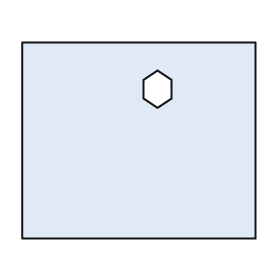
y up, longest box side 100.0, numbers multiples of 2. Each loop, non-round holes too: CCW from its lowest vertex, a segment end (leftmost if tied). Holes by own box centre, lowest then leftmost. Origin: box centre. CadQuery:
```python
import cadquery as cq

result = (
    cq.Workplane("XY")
    .moveTo(-50.0, -42.0)
    .lineTo(50.0, -42.0)
    .lineTo(50.0, 42.0)
    .lineTo(-50.0, 42.0)
    .close()
    .moveTo(8.0, 14.0)
    .lineTo(14.0, 18.0)
    .lineTo(14.0, 26.0)
    .lineTo(8.0, 30.0)
    .lineTo(2.0, 26.0)
    .lineTo(2.0, 18.0)
    .close()
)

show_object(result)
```